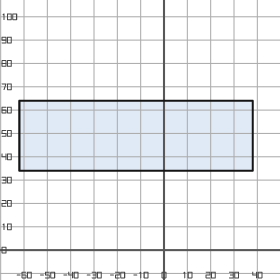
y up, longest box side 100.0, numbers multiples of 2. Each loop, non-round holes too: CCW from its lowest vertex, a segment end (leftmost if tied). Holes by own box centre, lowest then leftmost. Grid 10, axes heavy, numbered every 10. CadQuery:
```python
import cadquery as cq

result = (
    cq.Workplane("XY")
    .moveTo(-62.0, 34.0)
    .lineTo(38.0, 34.0)
    .lineTo(38.0, 64.0)
    .lineTo(-62.0, 64.0)
    .close()
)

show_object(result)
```